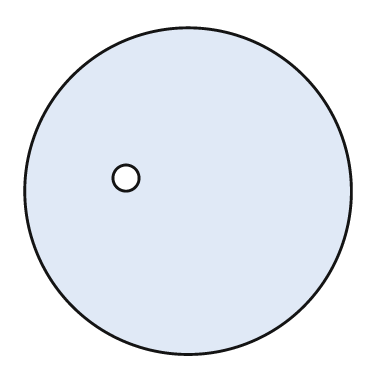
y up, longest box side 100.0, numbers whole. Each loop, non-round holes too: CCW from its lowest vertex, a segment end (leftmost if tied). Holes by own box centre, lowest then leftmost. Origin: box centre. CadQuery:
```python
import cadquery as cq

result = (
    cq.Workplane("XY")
    .moveTo(0.0, 0.0)
    .circle(50.0)
    .moveTo(-19.0, 4.0)
    .circle(4.0)
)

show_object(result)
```